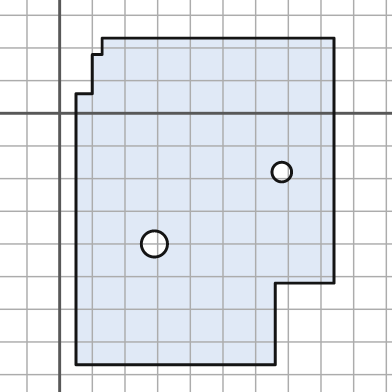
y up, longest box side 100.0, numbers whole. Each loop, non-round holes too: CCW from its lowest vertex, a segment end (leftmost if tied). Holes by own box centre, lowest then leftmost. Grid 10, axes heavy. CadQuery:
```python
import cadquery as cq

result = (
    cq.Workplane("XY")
    .moveTo(5.0, -77.0)
    .lineTo(66.0, -77.0)
    .lineTo(66.0, -52.0)
    .lineTo(84.0, -52.0)
    .lineTo(84.0, 23.0)
    .lineTo(13.0, 23.0)
    .lineTo(13.0, 18.0)
    .lineTo(10.0, 18.0)
    .lineTo(10.0, 6.0)
    .lineTo(5.0, 6.0)
    .close()
    .moveTo(29.0, -40.0)
    .circle(4.0)
    .moveTo(68.0, -18.0)
    .circle(3.0)
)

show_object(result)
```